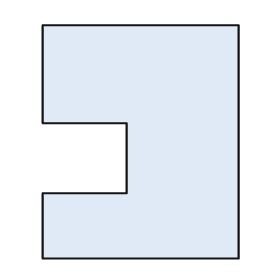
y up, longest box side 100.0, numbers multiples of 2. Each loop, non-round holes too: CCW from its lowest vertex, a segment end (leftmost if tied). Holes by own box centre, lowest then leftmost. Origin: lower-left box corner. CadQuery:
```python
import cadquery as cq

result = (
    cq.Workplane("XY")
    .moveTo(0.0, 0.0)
    .lineTo(84.0, 0.0)
    .lineTo(84.0, 100.0)
    .lineTo(0.0, 100.0)
    .lineTo(0.0, 58.0)
    .lineTo(36.0, 58.0)
    .lineTo(36.0, 28.0)
    .lineTo(0.0, 28.0)
    .close()
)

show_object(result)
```